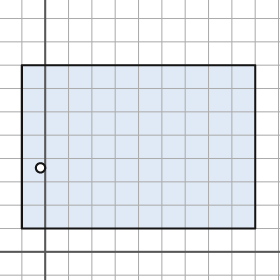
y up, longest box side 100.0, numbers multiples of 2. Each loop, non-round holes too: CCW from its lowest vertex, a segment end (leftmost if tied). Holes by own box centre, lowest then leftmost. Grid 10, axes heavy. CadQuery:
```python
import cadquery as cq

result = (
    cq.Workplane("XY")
    .moveTo(-10.0, 10.0)
    .lineTo(90.0, 10.0)
    .lineTo(90.0, 80.0)
    .lineTo(-10.0, 80.0)
    .close()
    .moveTo(-2.0, 36.0)
    .circle(2.0)
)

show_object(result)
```